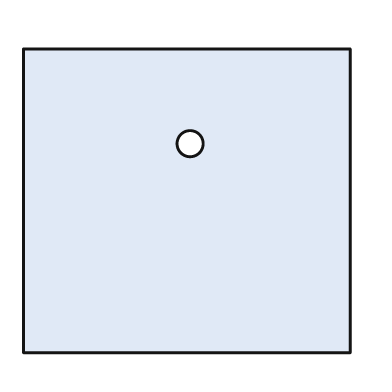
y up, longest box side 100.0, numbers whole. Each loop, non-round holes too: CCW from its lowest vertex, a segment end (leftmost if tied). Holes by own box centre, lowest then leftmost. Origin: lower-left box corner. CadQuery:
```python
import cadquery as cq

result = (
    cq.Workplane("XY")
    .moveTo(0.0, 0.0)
    .lineTo(100.0, 0.0)
    .lineTo(100.0, 93.0)
    .lineTo(0.0, 93.0)
    .close()
    .moveTo(51.0, 64.0)
    .circle(4.0)
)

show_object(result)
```